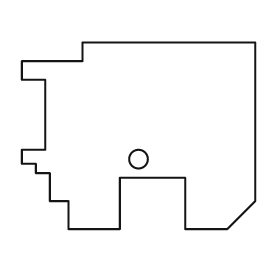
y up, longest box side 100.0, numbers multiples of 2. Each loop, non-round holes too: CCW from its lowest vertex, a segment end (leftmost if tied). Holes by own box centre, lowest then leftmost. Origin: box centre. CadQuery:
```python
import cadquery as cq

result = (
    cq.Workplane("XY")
    .moveTo(-30.0, -40.0)
    .lineTo(-8.0, -40.0)
    .lineTo(-8.0, -18.0)
    .lineTo(20.0, -18.0)
    .lineTo(20.0, -40.0)
    .lineTo(38.0, -40.0)
    .lineTo(50.0, -28.0)
    .lineTo(50.0, 40.0)
    .lineTo(-24.0, 40.0)
    .lineTo(-24.0, 32.0)
    .lineTo(-50.0, 32.0)
    .lineTo(-50.0, 24.0)
    .lineTo(-40.0, 24.0)
    .lineTo(-40.0, -6.0)
    .lineTo(-50.0, -6.0)
    .lineTo(-50.0, -12.0)
    .lineTo(-44.0, -12.0)
    .lineTo(-44.0, -16.0)
    .lineTo(-38.0, -16.0)
    .lineTo(-38.0, -28.0)
    .lineTo(-30.0, -28.0)
    .close()
    .moveTo(0.0, -10.0)
    .circle(4.0)
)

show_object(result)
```